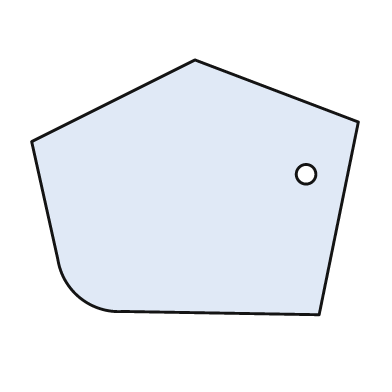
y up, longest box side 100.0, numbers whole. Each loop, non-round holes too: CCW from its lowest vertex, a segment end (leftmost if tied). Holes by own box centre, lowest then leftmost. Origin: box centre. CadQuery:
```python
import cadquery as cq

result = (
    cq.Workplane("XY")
    .moveTo(38.0, -39.0)
    .lineTo(50.0, 20.0)
    .lineTo(0.0, 39.0)
    .lineTo(-50.0, 14.0)
    .lineTo(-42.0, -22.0)
    .threePointArc((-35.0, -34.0), (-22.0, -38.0))
    .close()
    .moveTo(34.0, 4.0)
    .circle(3.0)
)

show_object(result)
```